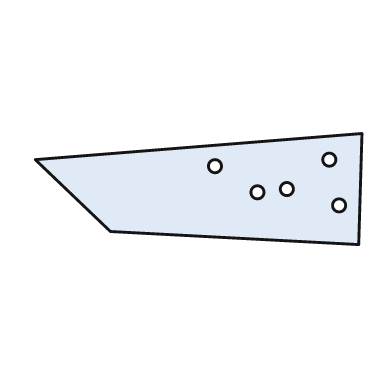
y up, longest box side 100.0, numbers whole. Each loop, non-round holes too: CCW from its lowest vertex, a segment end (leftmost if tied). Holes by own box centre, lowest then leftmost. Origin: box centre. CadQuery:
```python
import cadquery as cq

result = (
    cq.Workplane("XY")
    .moveTo(49.0, -17.0)
    .lineTo(50.0, 17.0)
    .lineTo(-50.0, 9.0)
    .lineTo(-27.0, -13.0)
    .close()
    .moveTo(43.0, -5.0)
    .circle(2.0)
    .moveTo(18.0, -1.0)
    .circle(2.0)
    .moveTo(27.0, 0.0)
    .circle(2.0)
    .moveTo(5.0, 7.0)
    .circle(2.0)
    .moveTo(40.0, 9.0)
    .circle(2.0)
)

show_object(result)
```